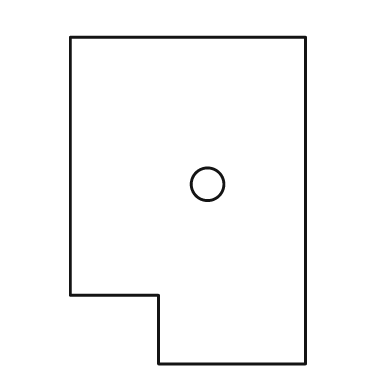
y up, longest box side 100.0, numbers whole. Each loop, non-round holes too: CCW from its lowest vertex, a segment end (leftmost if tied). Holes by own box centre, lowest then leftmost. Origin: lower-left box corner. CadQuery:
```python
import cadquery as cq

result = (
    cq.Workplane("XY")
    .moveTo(27.0, 0.0)
    .lineTo(72.0, 0.0)
    .lineTo(72.0, 100.0)
    .lineTo(0.0, 100.0)
    .lineTo(0.0, 21.0)
    .lineTo(27.0, 21.0)
    .close()
    .moveTo(42.0, 55.0)
    .circle(5.0)
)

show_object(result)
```